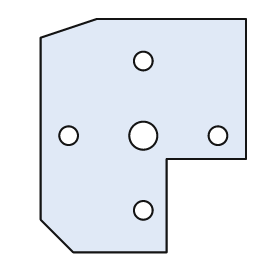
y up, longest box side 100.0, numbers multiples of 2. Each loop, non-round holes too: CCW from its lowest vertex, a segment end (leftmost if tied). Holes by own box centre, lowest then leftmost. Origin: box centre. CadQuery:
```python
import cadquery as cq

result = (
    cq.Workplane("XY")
    .moveTo(-30.0, -50.0)
    .lineTo(10.0, -50.0)
    .lineTo(10.0, -10.0)
    .lineTo(44.0, -10.0)
    .lineTo(44.0, 50.0)
    .lineTo(-20.0, 50.0)
    .lineTo(-44.0, 42.0)
    .lineTo(-44.0, -36.0)
    .close()
    .moveTo(0.0, -32.0)
    .circle(4.0)
    .moveTo(-32.0, 0.0)
    .circle(4.0)
    .moveTo(0.0, 0.0)
    .circle(6.0)
    .moveTo(32.0, 0.0)
    .circle(4.0)
    .moveTo(0.0, 32.0)
    .circle(4.0)
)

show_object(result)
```